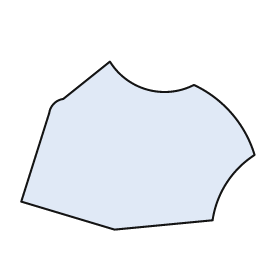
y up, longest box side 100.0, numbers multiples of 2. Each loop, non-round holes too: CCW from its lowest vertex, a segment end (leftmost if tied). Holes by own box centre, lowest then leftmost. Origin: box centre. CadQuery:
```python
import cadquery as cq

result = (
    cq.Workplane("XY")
    .moveTo(-10.0, -36.0)
    .lineTo(32.0, -32.0)
    .threePointArc((38.0, -16.0), (50.0, -4.0))
    .threePointArc((40.0, 14.0), (24.0, 26.0))
    .threePointArc((4.0, 24.0), (-12.0, 36.0))
    .lineTo(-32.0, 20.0)
    .threePointArc((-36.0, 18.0), (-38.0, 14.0))
    .lineTo(-50.0, -24.0)
    .close()
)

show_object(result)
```